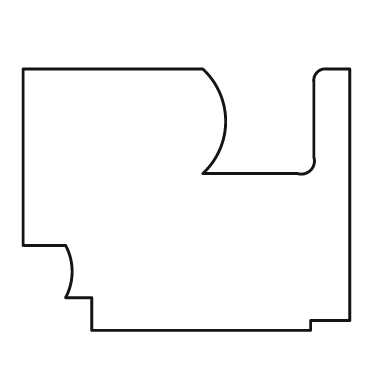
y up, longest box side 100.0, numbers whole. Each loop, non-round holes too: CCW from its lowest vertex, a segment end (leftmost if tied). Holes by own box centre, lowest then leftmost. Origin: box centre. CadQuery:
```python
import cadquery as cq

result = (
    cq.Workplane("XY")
    .moveTo(-29.0, -40.0)
    .lineTo(38.0, -40.0)
    .lineTo(38.0, -37.0)
    .lineTo(50.0, -37.0)
    .lineTo(50.0, 40.0)
    .lineTo(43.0, 40.0)
    .threePointArc((40.0, 39.0), (39.0, 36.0))
    .lineTo(39.0, 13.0)
    .threePointArc((38.0, 9.0), (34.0, 8.0))
    .lineTo(5.0, 8.0)
    .threePointArc((12.0, 24.0), (5.0, 40.0))
    .lineTo(-50.0, 40.0)
    .lineTo(-50.0, -14.0)
    .lineTo(-37.0, -14.0)
    .threePointArc((-35.0, -22.0), (-37.0, -30.0))
    .lineTo(-29.0, -30.0)
    .close()
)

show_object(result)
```